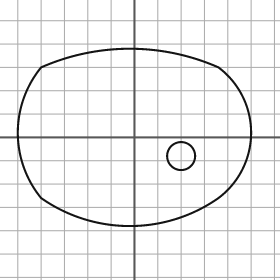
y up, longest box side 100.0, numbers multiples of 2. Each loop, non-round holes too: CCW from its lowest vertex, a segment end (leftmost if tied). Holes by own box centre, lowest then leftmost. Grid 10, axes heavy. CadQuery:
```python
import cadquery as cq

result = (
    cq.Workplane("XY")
    .moveTo(-40.0, -26.0)
    .threePointArc((-2.0, -38.0), (36.0, -26.0))
    .threePointArc((50.0, 2.0), (36.0, 30.0))
    .threePointArc((-2.0, 38.0), (-40.0, 30.0))
    .threePointArc((-50.0, 2.0), (-40.0, -26.0))
    .close()
    .moveTo(20.0, -8.0)
    .circle(6.0)
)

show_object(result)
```